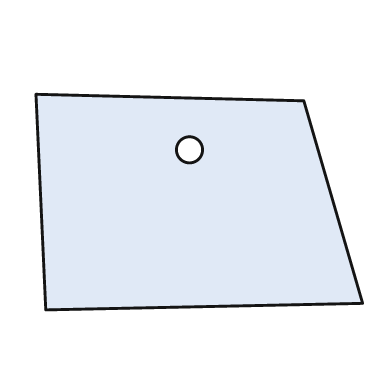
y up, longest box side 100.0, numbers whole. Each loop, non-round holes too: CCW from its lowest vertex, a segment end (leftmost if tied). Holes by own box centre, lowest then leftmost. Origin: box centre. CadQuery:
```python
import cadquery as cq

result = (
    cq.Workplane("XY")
    .moveTo(-47.0, -33.0)
    .lineTo(50.0, -31.0)
    .lineTo(32.0, 31.0)
    .lineTo(-50.0, 33.0)
    .close()
    .moveTo(-3.0, 16.0)
    .circle(4.0)
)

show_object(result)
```